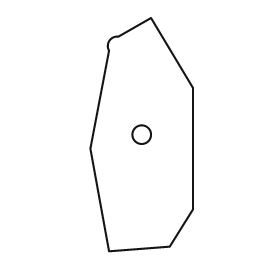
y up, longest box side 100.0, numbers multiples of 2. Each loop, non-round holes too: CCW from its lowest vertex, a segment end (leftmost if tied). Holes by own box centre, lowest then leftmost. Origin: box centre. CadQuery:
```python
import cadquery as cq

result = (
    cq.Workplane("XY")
    .moveTo(-14.0, -50.0)
    .lineTo(12.0, -48.0)
    .lineTo(22.0, -32.0)
    .lineTo(22.0, 20.0)
    .lineTo(4.0, 50.0)
    .lineTo(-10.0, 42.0)
    .threePointArc((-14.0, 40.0), (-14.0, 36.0))
    .lineTo(-22.0, -6.0)
    .close()
    .moveTo(0.0, 0.0)
    .circle(4.0)
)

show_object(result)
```